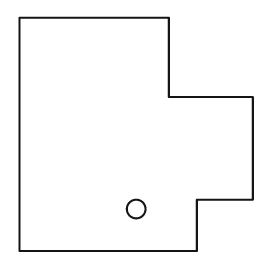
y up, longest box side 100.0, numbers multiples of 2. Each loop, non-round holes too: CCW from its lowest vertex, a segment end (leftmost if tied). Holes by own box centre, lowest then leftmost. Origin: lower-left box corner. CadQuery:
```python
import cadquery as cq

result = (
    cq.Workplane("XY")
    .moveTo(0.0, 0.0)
    .lineTo(76.0, 0.0)
    .lineTo(76.0, 22.0)
    .lineTo(100.0, 22.0)
    .lineTo(100.0, 66.0)
    .lineTo(64.0, 66.0)
    .lineTo(64.0, 100.0)
    .lineTo(0.0, 100.0)
    .close()
    .moveTo(50.0, 18.0)
    .circle(4.0)
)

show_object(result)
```